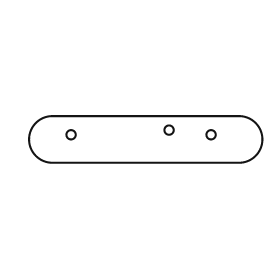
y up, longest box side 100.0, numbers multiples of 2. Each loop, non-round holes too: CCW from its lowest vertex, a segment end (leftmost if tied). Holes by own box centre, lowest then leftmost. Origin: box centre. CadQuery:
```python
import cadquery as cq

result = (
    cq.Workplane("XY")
    .moveTo(-40.0, -10.0)
    .lineTo(40.0, -10.0)
    .threePointArc((50.0, 0.0), (40.0, 10.0))
    .lineTo(-40.0, 10.0)
    .threePointArc((-50.0, 0.0), (-40.0, -10.0))
    .close()
    .moveTo(-32.0, 2.0)
    .circle(2.0)
    .moveTo(28.0, 2.0)
    .circle(2.0)
    .moveTo(10.0, 4.0)
    .circle(2.0)
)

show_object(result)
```